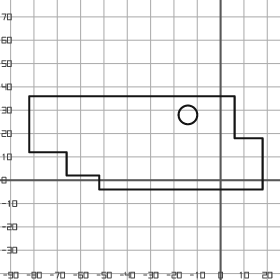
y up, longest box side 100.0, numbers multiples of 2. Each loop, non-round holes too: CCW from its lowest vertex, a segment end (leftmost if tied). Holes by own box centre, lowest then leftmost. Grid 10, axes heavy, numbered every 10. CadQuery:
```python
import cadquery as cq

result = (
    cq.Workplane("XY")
    .moveTo(-52.0, -4.0)
    .lineTo(18.0, -4.0)
    .lineTo(18.0, 18.0)
    .lineTo(6.0, 18.0)
    .lineTo(6.0, 36.0)
    .lineTo(-82.0, 36.0)
    .lineTo(-82.0, 12.0)
    .lineTo(-66.0, 12.0)
    .lineTo(-66.0, 2.0)
    .lineTo(-52.0, 2.0)
    .close()
    .moveTo(-14.0, 28.0)
    .circle(4.0)
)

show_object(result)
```